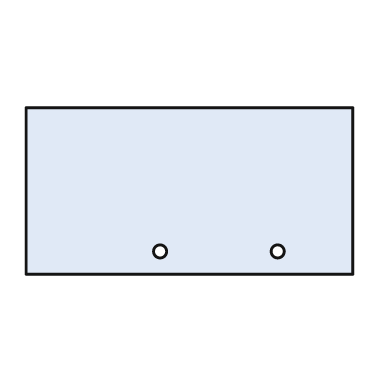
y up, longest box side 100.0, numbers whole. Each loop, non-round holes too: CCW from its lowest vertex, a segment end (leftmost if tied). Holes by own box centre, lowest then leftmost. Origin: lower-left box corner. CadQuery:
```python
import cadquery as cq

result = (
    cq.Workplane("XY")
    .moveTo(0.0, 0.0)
    .lineTo(100.0, 0.0)
    .lineTo(100.0, 51.0)
    .lineTo(0.0, 51.0)
    .close()
    .moveTo(41.0, 7.0)
    .circle(2.0)
    .moveTo(77.0, 7.0)
    .circle(2.0)
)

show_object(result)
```